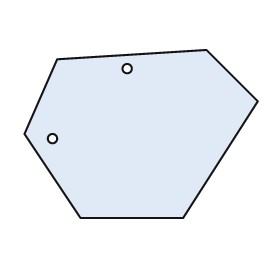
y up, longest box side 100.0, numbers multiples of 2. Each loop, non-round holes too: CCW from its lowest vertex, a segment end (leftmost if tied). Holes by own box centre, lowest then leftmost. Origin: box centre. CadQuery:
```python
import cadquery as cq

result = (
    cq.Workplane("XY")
    .moveTo(-26.0, -36.0)
    .lineTo(18.0, -36.0)
    .lineTo(50.0, 14.0)
    .lineTo(28.0, 36.0)
    .lineTo(-36.0, 32.0)
    .lineTo(-50.0, 0.0)
    .close()
    .moveTo(-38.0, -2.0)
    .circle(2.0)
    .moveTo(-6.0, 28.0)
    .circle(2.0)
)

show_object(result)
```